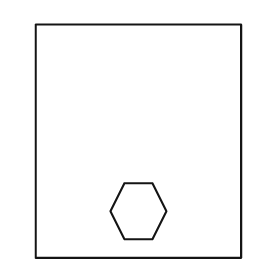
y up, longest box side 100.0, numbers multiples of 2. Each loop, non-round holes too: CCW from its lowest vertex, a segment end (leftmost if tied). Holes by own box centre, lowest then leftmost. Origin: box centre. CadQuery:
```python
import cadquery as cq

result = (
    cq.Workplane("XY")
    .moveTo(-44.0, -50.0)
    .lineTo(44.0, -50.0)
    .lineTo(44.0, 50.0)
    .lineTo(-44.0, 50.0)
    .close()
    .moveTo(-6.0, -42.0)
    .lineTo(6.0, -42.0)
    .lineTo(12.0, -30.0)
    .lineTo(6.0, -18.0)
    .lineTo(-6.0, -18.0)
    .lineTo(-12.0, -30.0)
    .close()
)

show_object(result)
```